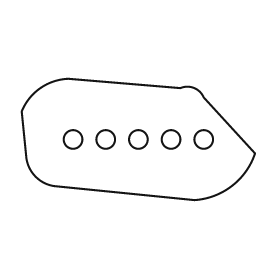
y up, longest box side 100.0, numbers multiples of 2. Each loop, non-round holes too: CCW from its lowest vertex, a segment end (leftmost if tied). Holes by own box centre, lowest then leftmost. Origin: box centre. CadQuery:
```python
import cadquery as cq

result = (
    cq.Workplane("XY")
    .moveTo(24.0, -26.0)
    .threePointArc((40.0, -20.0), (50.0, -6.0))
    .lineTo(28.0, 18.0)
    .threePointArc((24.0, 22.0), (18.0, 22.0))
    .lineTo(-30.0, 26.0)
    .threePointArc((-42.0, 22.0), (-50.0, 12.0))
    .lineTo(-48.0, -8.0)
    .threePointArc((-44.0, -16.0), (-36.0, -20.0))
    .close()
    .moveTo(-28.0, 0.0)
    .circle(4.0)
    .moveTo(-14.0, 0.0)
    .circle(4.0)
    .moveTo(0.0, 0.0)
    .circle(4.0)
    .moveTo(14.0, 0.0)
    .circle(4.0)
    .moveTo(28.0, 0.0)
    .circle(4.0)
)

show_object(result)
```